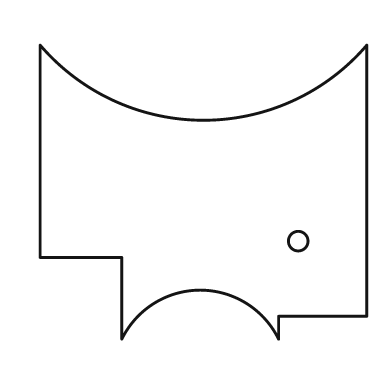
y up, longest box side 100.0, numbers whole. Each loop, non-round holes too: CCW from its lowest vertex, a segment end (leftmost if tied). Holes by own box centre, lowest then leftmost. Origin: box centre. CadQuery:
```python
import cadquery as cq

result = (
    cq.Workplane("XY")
    .moveTo(-25.0, -45.0)
    .threePointArc((-1.0, -30.0), (23.0, -45.0))
    .lineTo(23.0, -38.0)
    .lineTo(50.0, -38.0)
    .lineTo(50.0, 45.0)
    .threePointArc((0.0, 22.0), (-50.0, 45.0))
    .lineTo(-50.0, -20.0)
    .lineTo(-25.0, -20.0)
    .close()
    .moveTo(29.0, -15.0)
    .circle(3.0)
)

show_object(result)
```